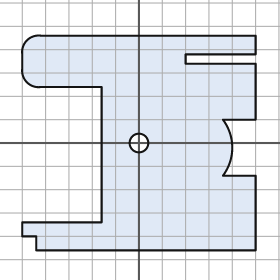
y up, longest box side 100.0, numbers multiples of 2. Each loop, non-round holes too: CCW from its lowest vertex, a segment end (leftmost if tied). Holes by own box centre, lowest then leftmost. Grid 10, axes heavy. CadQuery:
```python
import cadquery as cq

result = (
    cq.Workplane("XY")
    .moveTo(-44.0, -46.0)
    .lineTo(50.0, -46.0)
    .lineTo(50.0, -14.0)
    .lineTo(36.0, -14.0)
    .threePointArc((40.0, -2.0), (36.0, 10.0))
    .lineTo(50.0, 10.0)
    .lineTo(50.0, 34.0)
    .lineTo(20.0, 34.0)
    .lineTo(20.0, 38.0)
    .lineTo(50.0, 38.0)
    .lineTo(50.0, 46.0)
    .lineTo(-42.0, 46.0)
    .threePointArc((-48.0, 44.0), (-50.0, 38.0))
    .lineTo(-50.0, 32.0)
    .threePointArc((-48.0, 26.0), (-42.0, 24.0))
    .lineTo(-16.0, 24.0)
    .lineTo(-16.0, -34.0)
    .lineTo(-50.0, -34.0)
    .lineTo(-50.0, -40.0)
    .lineTo(-44.0, -40.0)
    .close()
    .moveTo(0.0, 0.0)
    .circle(4.0)
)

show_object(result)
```